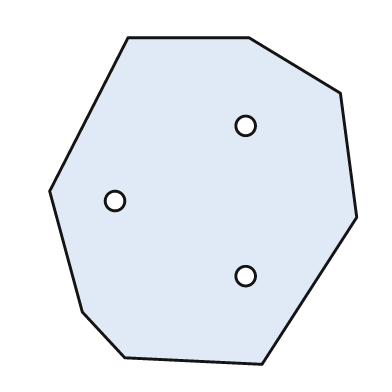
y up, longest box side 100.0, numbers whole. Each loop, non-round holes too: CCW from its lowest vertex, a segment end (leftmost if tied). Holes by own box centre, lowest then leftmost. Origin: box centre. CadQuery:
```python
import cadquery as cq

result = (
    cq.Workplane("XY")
    .moveTo(18.0, -50.0)
    .lineTo(47.0, -5.0)
    .lineTo(42.0, 33.0)
    .lineTo(14.0, 50.0)
    .lineTo(-23.0, 50.0)
    .lineTo(-47.0, 3.0)
    .lineTo(-37.0, -34.0)
    .lineTo(-24.0, -48.0)
    .close()
    .moveTo(13.0, -23.0)
    .circle(3.0)
    .moveTo(-27.0, 0.0)
    .circle(3.0)
    .moveTo(13.0, 23.0)
    .circle(3.0)
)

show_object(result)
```